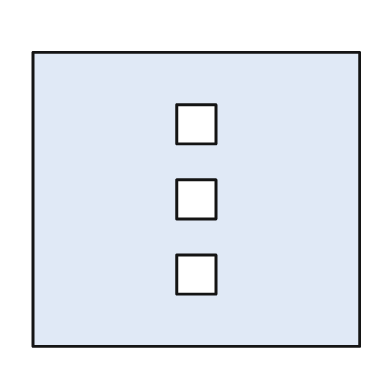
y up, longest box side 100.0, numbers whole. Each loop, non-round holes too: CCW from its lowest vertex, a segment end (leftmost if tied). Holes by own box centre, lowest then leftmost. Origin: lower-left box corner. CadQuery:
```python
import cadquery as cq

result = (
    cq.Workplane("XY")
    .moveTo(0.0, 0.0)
    .lineTo(100.0, 0.0)
    .lineTo(100.0, 90.0)
    .lineTo(0.0, 90.0)
    .close()
    .moveTo(44.0, 16.0)
    .lineTo(56.0, 16.0)
    .lineTo(56.0, 28.0)
    .lineTo(44.0, 28.0)
    .close()
    .moveTo(44.0, 39.0)
    .lineTo(56.0, 39.0)
    .lineTo(56.0, 51.0)
    .lineTo(44.0, 51.0)
    .close()
    .moveTo(44.0, 62.0)
    .lineTo(56.0, 62.0)
    .lineTo(56.0, 74.0)
    .lineTo(44.0, 74.0)
    .close()
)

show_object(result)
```